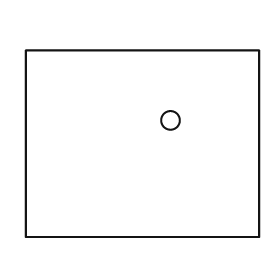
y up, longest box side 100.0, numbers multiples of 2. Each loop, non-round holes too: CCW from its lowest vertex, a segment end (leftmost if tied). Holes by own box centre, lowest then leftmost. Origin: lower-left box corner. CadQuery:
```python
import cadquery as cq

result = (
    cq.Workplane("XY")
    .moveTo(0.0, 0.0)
    .lineTo(100.0, 0.0)
    .lineTo(100.0, 80.0)
    .lineTo(0.0, 80.0)
    .close()
    .moveTo(62.0, 50.0)
    .circle(4.0)
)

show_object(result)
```